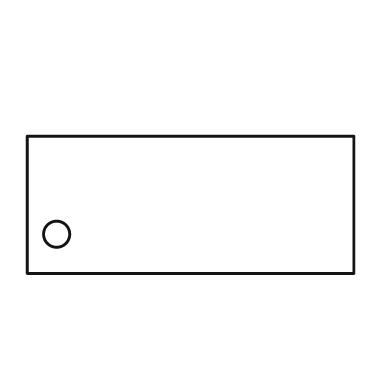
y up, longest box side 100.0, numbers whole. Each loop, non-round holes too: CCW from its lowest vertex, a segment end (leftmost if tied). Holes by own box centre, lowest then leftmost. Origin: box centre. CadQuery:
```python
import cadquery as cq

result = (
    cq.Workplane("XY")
    .moveTo(-50.0, -21.0)
    .lineTo(50.0, -21.0)
    .lineTo(50.0, 21.0)
    .lineTo(-50.0, 21.0)
    .close()
    .moveTo(-41.0, -9.0)
    .circle(4.0)
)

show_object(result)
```